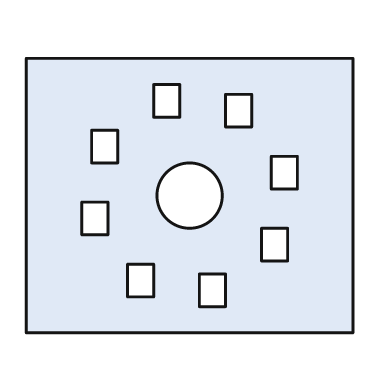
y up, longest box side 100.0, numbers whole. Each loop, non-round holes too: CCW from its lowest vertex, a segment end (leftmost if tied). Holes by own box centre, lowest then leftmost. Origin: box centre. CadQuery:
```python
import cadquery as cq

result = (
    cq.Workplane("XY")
    .moveTo(-50.0, -42.0)
    .lineTo(50.0, -42.0)
    .lineTo(50.0, 42.0)
    .lineTo(-50.0, 42.0)
    .close()
    .moveTo(3.0, -34.0)
    .lineTo(11.0, -34.0)
    .lineTo(11.0, -24.0)
    .lineTo(3.0, -24.0)
    .close()
    .moveTo(-19.0, -31.0)
    .lineTo(-11.0, -31.0)
    .lineTo(-11.0, -21.0)
    .lineTo(-19.0, -21.0)
    .close()
    .moveTo(22.0, -20.0)
    .lineTo(30.0, -20.0)
    .lineTo(30.0, -10.0)
    .lineTo(22.0, -10.0)
    .close()
    .moveTo(-33.0, -12.0)
    .lineTo(-25.0, -12.0)
    .lineTo(-25.0, -2.0)
    .lineTo(-33.0, -2.0)
    .close()
    .moveTo(0.0, 0.0)
    .circle(10.0)
    .moveTo(25.0, 2.0)
    .lineTo(33.0, 2.0)
    .lineTo(33.0, 12.0)
    .lineTo(25.0, 12.0)
    .close()
    .moveTo(-30.0, 10.0)
    .lineTo(-22.0, 10.0)
    .lineTo(-22.0, 20.0)
    .lineTo(-30.0, 20.0)
    .close()
    .moveTo(11.0, 21.0)
    .lineTo(19.0, 21.0)
    .lineTo(19.0, 31.0)
    .lineTo(11.0, 31.0)
    .close()
    .moveTo(-11.0, 24.0)
    .lineTo(-3.0, 24.0)
    .lineTo(-3.0, 34.0)
    .lineTo(-11.0, 34.0)
    .close()
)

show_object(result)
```